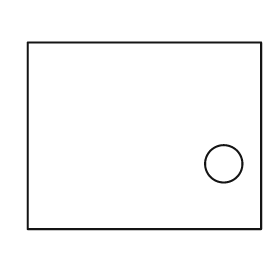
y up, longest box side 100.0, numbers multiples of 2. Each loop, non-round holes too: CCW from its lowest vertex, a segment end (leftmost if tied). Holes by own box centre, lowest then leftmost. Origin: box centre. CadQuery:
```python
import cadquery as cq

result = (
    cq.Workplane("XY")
    .moveTo(-50.0, -40.0)
    .lineTo(50.0, -40.0)
    .lineTo(50.0, 40.0)
    .lineTo(-50.0, 40.0)
    .close()
    .moveTo(34.0, -12.0)
    .circle(8.0)
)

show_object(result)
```